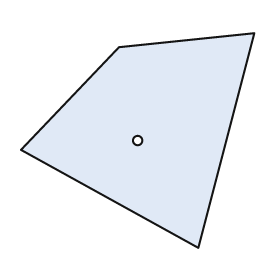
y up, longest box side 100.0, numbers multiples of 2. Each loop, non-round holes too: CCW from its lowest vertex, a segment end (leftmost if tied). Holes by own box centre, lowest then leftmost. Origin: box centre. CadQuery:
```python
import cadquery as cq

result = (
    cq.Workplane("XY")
    .moveTo(26.0, -46.0)
    .lineTo(50.0, 46.0)
    .lineTo(-8.0, 40.0)
    .lineTo(-50.0, -4.0)
    .close()
    .moveTo(0.0, 0.0)
    .circle(2.0)
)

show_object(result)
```